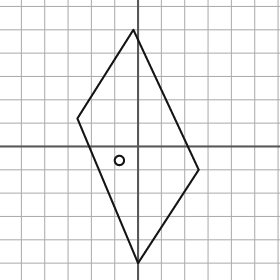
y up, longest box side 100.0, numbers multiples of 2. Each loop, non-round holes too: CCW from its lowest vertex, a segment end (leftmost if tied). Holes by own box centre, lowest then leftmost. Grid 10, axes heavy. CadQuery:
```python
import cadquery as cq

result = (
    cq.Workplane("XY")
    .moveTo(0.0, -50.0)
    .lineTo(26.0, -10.0)
    .lineTo(-2.0, 50.0)
    .lineTo(-26.0, 12.0)
    .close()
    .moveTo(-8.0, -6.0)
    .circle(2.0)
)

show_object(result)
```